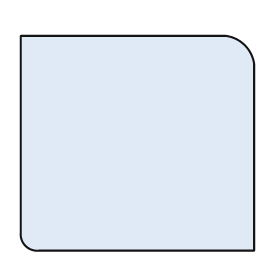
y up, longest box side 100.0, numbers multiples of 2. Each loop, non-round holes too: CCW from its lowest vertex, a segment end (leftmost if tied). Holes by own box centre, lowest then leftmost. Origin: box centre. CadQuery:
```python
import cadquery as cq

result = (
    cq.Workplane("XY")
    .moveTo(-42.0, -46.0)
    .lineTo(50.0, -46.0)
    .lineTo(50.0, 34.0)
    .threePointArc((46.0, 42.0), (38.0, 46.0))
    .lineTo(-50.0, 46.0)
    .lineTo(-50.0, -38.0)
    .threePointArc((-48.0, -44.0), (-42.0, -46.0))
    .close()
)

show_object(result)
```